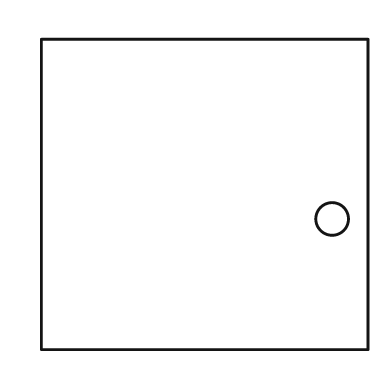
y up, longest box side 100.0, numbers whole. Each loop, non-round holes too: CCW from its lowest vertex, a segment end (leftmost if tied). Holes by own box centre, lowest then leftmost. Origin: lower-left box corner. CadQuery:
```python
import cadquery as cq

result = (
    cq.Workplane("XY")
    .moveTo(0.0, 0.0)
    .lineTo(100.0, 0.0)
    .lineTo(100.0, 95.0)
    .lineTo(0.0, 95.0)
    .close()
    .moveTo(89.0, 40.0)
    .circle(5.0)
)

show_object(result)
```